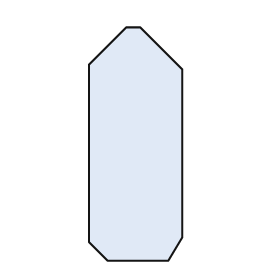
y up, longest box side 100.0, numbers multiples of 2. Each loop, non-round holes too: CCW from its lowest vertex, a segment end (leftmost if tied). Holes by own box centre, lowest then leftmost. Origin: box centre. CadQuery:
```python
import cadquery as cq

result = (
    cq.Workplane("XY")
    .moveTo(-12.0, -50.0)
    .lineTo(14.0, -50.0)
    .lineTo(20.0, -40.0)
    .lineTo(20.0, 32.0)
    .lineTo(2.0, 50.0)
    .lineTo(-4.0, 50.0)
    .lineTo(-20.0, 34.0)
    .lineTo(-20.0, -42.0)
    .close()
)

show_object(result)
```